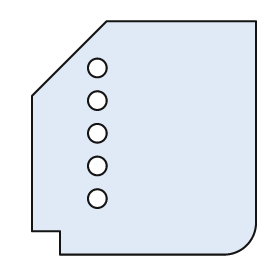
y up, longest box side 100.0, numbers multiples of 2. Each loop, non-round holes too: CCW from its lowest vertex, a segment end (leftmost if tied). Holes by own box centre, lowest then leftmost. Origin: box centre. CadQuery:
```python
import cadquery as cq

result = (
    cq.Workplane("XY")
    .moveTo(-36.0, -50.0)
    .lineTo(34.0, -50.0)
    .threePointArc((44.0, -46.0), (48.0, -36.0))
    .lineTo(48.0, 50.0)
    .lineTo(-16.0, 50.0)
    .lineTo(-48.0, 18.0)
    .lineTo(-48.0, -40.0)
    .lineTo(-36.0, -40.0)
    .close()
    .moveTo(-20.0, -26.0)
    .circle(4.0)
    .moveTo(-20.0, -12.0)
    .circle(4.0)
    .moveTo(-20.0, 2.0)
    .circle(4.0)
    .moveTo(-20.0, 16.0)
    .circle(4.0)
    .moveTo(-20.0, 30.0)
    .circle(4.0)
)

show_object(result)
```